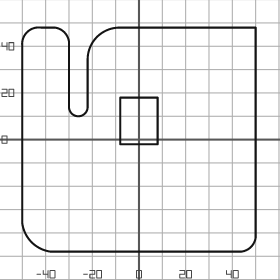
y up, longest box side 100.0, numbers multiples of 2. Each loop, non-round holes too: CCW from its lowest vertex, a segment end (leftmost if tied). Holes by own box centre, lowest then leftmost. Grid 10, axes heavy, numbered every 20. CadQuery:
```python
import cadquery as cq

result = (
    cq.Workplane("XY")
    .moveTo(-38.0, -48.0)
    .lineTo(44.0, -48.0)
    .threePointArc((48.0, -46.0), (50.0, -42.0))
    .lineTo(50.0, 48.0)
    .lineTo(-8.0, 48.0)
    .threePointArc((-18.0, 44.0), (-22.0, 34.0))
    .lineTo(-22.0, 14.0)
    .threePointArc((-26.0, 10.0), (-30.0, 14.0))
    .lineTo(-30.0, 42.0)
    .threePointArc((-32.0, 46.0), (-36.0, 48.0))
    .lineTo(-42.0, 48.0)
    .threePointArc((-48.0, 46.0), (-50.0, 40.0))
    .lineTo(-50.0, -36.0)
    .threePointArc((-46.0, -44.0), (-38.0, -48.0))
    .close()
    .moveTo(-8.0, -2.0)
    .lineTo(8.0, -2.0)
    .lineTo(8.0, 18.0)
    .lineTo(-8.0, 18.0)
    .close()
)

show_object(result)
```